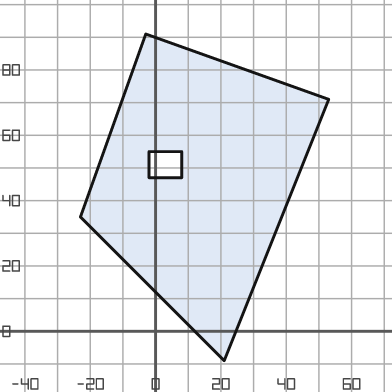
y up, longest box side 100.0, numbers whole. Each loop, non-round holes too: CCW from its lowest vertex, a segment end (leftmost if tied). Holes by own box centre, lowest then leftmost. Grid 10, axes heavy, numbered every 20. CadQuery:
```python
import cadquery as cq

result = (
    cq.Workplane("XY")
    .moveTo(21.0, -9.0)
    .lineTo(53.0, 71.0)
    .lineTo(-3.0, 91.0)
    .lineTo(-23.0, 35.0)
    .close()
    .moveTo(-2.0, 47.0)
    .lineTo(8.0, 47.0)
    .lineTo(8.0, 55.0)
    .lineTo(-2.0, 55.0)
    .close()
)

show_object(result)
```